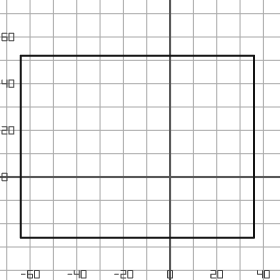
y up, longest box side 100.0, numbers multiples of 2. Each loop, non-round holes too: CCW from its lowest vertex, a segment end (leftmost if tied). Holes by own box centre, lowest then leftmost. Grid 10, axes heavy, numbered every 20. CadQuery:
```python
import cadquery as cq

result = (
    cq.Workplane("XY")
    .moveTo(-64.0, -26.0)
    .lineTo(36.0, -26.0)
    .lineTo(36.0, 52.0)
    .lineTo(-64.0, 52.0)
    .close()
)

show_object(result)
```